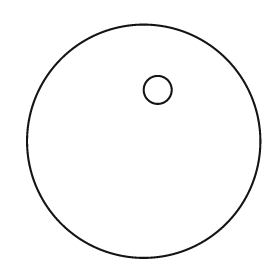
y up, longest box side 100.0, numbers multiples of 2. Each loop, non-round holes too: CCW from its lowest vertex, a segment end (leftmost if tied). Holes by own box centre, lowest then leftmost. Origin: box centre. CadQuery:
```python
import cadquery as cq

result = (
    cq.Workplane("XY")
    .moveTo(0.0, 0.0)
    .circle(50.0)
    .moveTo(6.0, 22.0)
    .circle(6.0)
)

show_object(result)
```